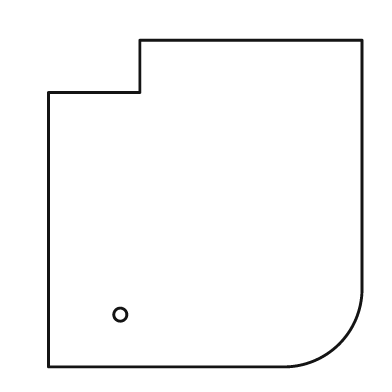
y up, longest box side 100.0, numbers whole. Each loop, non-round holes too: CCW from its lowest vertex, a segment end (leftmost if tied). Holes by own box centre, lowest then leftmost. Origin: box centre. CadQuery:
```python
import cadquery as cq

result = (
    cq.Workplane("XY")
    .moveTo(-48.0, -50.0)
    .lineTo(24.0, -50.0)
    .threePointArc((41.0, -43.0), (48.0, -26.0))
    .lineTo(48.0, 50.0)
    .lineTo(-20.0, 50.0)
    .lineTo(-20.0, 34.0)
    .lineTo(-48.0, 34.0)
    .close()
    .moveTo(-26.0, -34.0)
    .circle(2.0)
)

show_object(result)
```